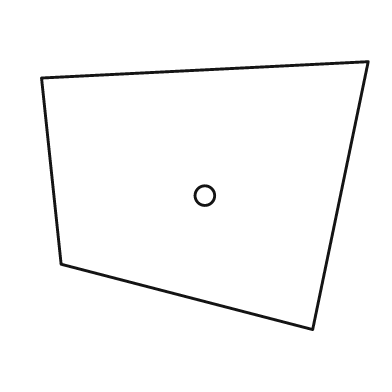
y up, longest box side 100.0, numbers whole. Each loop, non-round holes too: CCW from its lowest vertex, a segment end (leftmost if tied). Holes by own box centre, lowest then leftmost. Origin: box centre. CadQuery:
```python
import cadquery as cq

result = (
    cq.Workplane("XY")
    .moveTo(33.0, -41.0)
    .lineTo(50.0, 41.0)
    .lineTo(-50.0, 36.0)
    .lineTo(-44.0, -21.0)
    .close()
    .moveTo(0.0, 0.0)
    .circle(3.0)
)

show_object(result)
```